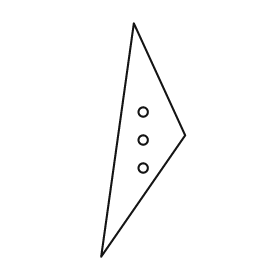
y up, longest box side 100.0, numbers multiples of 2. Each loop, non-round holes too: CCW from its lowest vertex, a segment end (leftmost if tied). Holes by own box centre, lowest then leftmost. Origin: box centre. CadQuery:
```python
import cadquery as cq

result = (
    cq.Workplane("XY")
    .moveTo(-18.0, -50.0)
    .lineTo(18.0, 2.0)
    .lineTo(-4.0, 50.0)
    .close()
    .moveTo(0.0, -12.0)
    .circle(2.0)
    .moveTo(0.0, 0.0)
    .circle(2.0)
    .moveTo(0.0, 12.0)
    .circle(2.0)
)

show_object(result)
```